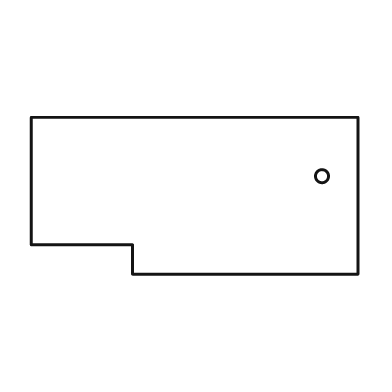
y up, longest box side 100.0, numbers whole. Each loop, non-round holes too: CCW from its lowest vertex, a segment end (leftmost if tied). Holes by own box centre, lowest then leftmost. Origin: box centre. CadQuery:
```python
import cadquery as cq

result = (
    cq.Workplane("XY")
    .moveTo(-19.0, -24.0)
    .lineTo(50.0, -24.0)
    .lineTo(50.0, 24.0)
    .lineTo(-50.0, 24.0)
    .lineTo(-50.0, -15.0)
    .lineTo(-19.0, -15.0)
    .close()
    .moveTo(39.0, 6.0)
    .circle(2.0)
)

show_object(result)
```